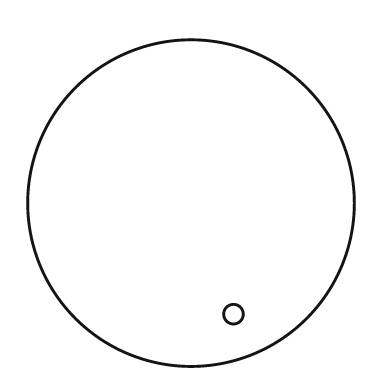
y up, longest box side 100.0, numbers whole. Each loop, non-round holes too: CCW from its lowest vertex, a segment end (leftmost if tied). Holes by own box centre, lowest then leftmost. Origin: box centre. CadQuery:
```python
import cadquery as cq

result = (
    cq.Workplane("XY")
    .moveTo(0.0, 0.0)
    .circle(50.0)
    .moveTo(13.0, -34.0)
    .circle(3.0)
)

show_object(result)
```